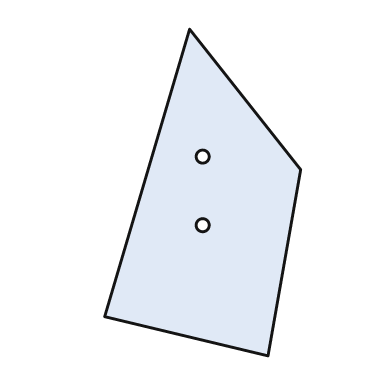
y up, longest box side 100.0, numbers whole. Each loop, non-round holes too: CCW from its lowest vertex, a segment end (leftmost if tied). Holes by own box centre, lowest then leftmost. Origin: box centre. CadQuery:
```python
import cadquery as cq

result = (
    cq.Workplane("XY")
    .moveTo(20.0, -50.0)
    .lineTo(30.0, 7.0)
    .lineTo(-4.0, 50.0)
    .lineTo(-30.0, -38.0)
    .close()
    .moveTo(0.0, -10.0)
    .circle(2.0)
    .moveTo(0.0, 11.0)
    .circle(2.0)
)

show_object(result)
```